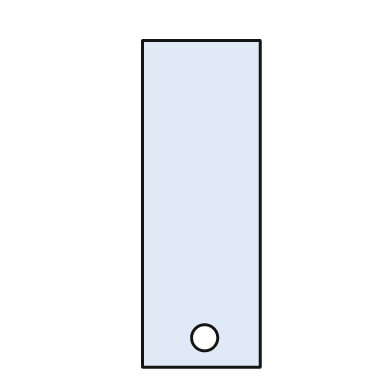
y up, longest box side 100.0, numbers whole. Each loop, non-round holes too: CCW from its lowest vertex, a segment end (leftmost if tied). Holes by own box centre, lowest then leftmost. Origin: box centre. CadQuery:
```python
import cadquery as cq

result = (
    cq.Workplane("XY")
    .moveTo(-18.0, -50.0)
    .lineTo(18.0, -50.0)
    .lineTo(18.0, 50.0)
    .lineTo(-18.0, 50.0)
    .close()
    .moveTo(1.0, -41.0)
    .circle(4.0)
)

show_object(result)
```